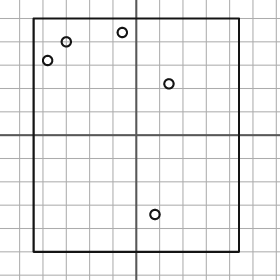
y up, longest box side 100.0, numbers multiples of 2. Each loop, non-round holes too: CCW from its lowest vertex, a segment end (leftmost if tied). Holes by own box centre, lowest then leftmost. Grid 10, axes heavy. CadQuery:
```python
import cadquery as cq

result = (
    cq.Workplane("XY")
    .moveTo(-44.0, -50.0)
    .lineTo(44.0, -50.0)
    .lineTo(44.0, 50.0)
    .lineTo(-44.0, 50.0)
    .close()
    .moveTo(8.0, -34.0)
    .circle(2.0)
    .moveTo(14.0, 22.0)
    .circle(2.0)
    .moveTo(-38.0, 32.0)
    .circle(2.0)
    .moveTo(-30.0, 40.0)
    .circle(2.0)
    .moveTo(-6.0, 44.0)
    .circle(2.0)
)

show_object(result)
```